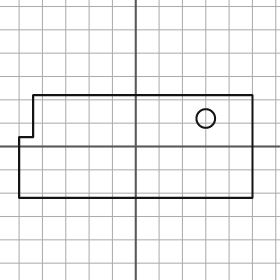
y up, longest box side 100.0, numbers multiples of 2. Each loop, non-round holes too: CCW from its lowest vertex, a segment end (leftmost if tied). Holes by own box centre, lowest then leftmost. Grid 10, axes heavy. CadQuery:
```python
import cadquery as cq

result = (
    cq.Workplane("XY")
    .moveTo(-50.0, -22.0)
    .lineTo(50.0, -22.0)
    .lineTo(50.0, 22.0)
    .lineTo(-44.0, 22.0)
    .lineTo(-44.0, 4.0)
    .lineTo(-50.0, 4.0)
    .close()
    .moveTo(30.0, 12.0)
    .circle(4.0)
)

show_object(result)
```